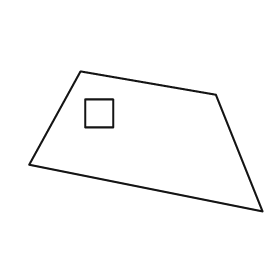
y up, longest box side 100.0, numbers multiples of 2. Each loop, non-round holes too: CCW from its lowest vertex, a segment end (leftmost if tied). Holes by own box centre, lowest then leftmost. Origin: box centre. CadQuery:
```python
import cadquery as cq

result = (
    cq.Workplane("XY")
    .moveTo(50.0, -30.0)
    .lineTo(30.0, 20.0)
    .lineTo(-28.0, 30.0)
    .lineTo(-50.0, -10.0)
    .close()
    .moveTo(-26.0, 6.0)
    .lineTo(-14.0, 6.0)
    .lineTo(-14.0, 18.0)
    .lineTo(-26.0, 18.0)
    .close()
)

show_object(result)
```